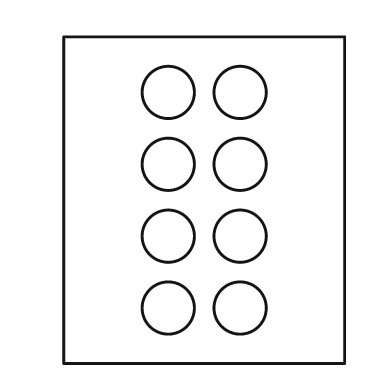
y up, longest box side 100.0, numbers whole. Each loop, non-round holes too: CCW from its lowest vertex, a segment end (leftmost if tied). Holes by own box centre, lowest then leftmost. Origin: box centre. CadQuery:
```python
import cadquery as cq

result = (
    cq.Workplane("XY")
    .moveTo(-43.0, -50.0)
    .lineTo(43.0, -50.0)
    .lineTo(43.0, 50.0)
    .lineTo(-43.0, 50.0)
    .close()
    .moveTo(-11.0, -33.0)
    .circle(8.0)
    .moveTo(11.0, -33.0)
    .circle(8.0)
    .moveTo(-11.0, -11.0)
    .circle(8.0)
    .moveTo(11.0, -11.0)
    .circle(8.0)
    .moveTo(-11.0, 11.0)
    .circle(8.0)
    .moveTo(11.0, 11.0)
    .circle(8.0)
    .moveTo(-11.0, 33.0)
    .circle(8.0)
    .moveTo(11.0, 33.0)
    .circle(8.0)
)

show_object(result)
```